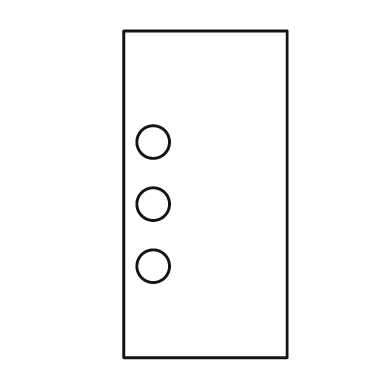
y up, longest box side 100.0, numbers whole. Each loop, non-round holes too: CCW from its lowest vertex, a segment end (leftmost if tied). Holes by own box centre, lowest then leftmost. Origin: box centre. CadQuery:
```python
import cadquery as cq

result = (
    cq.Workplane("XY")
    .moveTo(-25.0, -50.0)
    .lineTo(25.0, -50.0)
    .lineTo(25.0, 50.0)
    .lineTo(-25.0, 50.0)
    .close()
    .moveTo(-16.0, -22.0)
    .circle(5.0)
    .moveTo(-16.0, -3.0)
    .circle(5.0)
    .moveTo(-16.0, 16.0)
    .circle(5.0)
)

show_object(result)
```